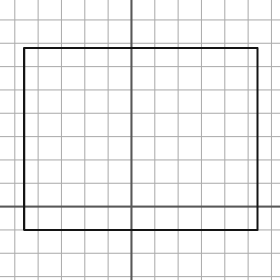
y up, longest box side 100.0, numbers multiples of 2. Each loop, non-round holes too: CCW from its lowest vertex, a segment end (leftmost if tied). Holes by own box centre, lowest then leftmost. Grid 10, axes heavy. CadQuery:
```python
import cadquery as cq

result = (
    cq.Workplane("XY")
    .moveTo(-46.0, -10.0)
    .lineTo(54.0, -10.0)
    .lineTo(54.0, 68.0)
    .lineTo(-46.0, 68.0)
    .close()
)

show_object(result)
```